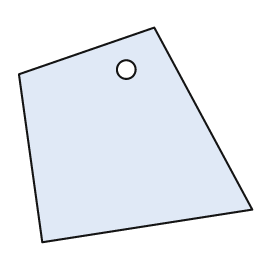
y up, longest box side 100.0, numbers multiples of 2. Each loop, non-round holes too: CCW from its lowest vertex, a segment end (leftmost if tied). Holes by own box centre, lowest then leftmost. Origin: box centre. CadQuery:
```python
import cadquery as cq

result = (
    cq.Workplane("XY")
    .moveTo(-40.0, -46.0)
    .lineTo(50.0, -32.0)
    .lineTo(8.0, 46.0)
    .lineTo(-50.0, 26.0)
    .close()
    .moveTo(-4.0, 28.0)
    .circle(4.0)
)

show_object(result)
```